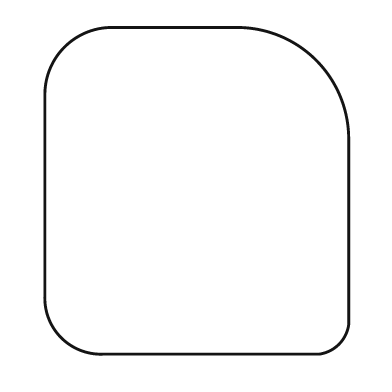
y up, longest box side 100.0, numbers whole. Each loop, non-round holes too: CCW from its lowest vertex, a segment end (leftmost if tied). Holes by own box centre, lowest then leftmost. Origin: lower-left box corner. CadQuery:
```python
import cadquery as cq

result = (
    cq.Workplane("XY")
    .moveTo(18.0, 0.0)
    .lineTo(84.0, 0.0)
    .threePointArc((90.0, 3.0), (93.0, 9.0))
    .lineTo(93.0, 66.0)
    .threePointArc((83.0, 90.0), (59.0, 100.0))
    .lineTo(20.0, 100.0)
    .threePointArc((6.0, 94.0), (0.0, 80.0))
    .lineTo(0.0, 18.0)
    .threePointArc((5.0, 5.0), (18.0, 0.0))
    .close()
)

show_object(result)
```